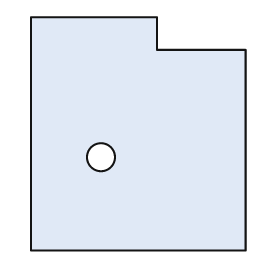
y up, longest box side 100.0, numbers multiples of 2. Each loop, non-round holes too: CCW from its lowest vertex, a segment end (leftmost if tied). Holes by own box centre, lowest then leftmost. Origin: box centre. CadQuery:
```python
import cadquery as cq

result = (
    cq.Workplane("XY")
    .moveTo(-46.0, -50.0)
    .lineTo(46.0, -50.0)
    .lineTo(46.0, 36.0)
    .lineTo(8.0, 36.0)
    .lineTo(8.0, 50.0)
    .lineTo(-46.0, 50.0)
    .close()
    .moveTo(-16.0, -10.0)
    .circle(6.0)
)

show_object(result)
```